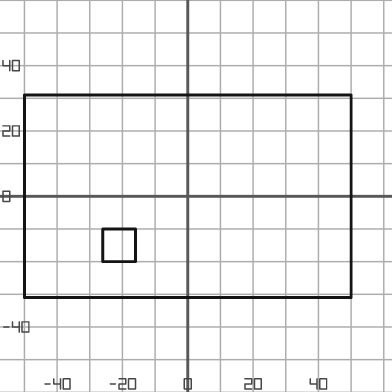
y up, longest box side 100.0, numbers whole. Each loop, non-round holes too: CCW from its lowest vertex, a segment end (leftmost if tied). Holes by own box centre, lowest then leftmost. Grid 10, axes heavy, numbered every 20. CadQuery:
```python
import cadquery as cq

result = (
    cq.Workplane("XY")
    .moveTo(-50.0, -31.0)
    .lineTo(50.0, -31.0)
    .lineTo(50.0, 31.0)
    .lineTo(-50.0, 31.0)
    .close()
    .moveTo(-26.0, -20.0)
    .lineTo(-16.0, -20.0)
    .lineTo(-16.0, -10.0)
    .lineTo(-26.0, -10.0)
    .close()
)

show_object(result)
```